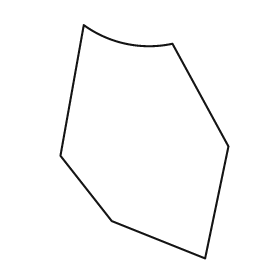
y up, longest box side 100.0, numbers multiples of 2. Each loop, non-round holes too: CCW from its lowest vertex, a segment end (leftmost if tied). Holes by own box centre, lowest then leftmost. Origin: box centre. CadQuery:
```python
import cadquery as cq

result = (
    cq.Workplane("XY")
    .moveTo(26.0, -50.0)
    .lineTo(36.0, -2.0)
    .lineTo(12.0, 42.0)
    .threePointArc((-8.0, 42.0), (-26.0, 50.0))
    .lineTo(-36.0, -6.0)
    .lineTo(-14.0, -34.0)
    .close()
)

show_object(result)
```